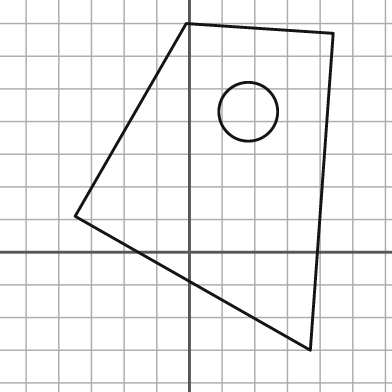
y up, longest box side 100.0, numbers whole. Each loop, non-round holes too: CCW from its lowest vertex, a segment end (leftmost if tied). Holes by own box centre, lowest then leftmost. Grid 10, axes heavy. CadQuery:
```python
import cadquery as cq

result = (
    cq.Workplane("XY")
    .moveTo(37.0, -30.0)
    .lineTo(44.0, 67.0)
    .lineTo(-1.0, 70.0)
    .lineTo(-35.0, 11.0)
    .close()
    .moveTo(18.0, 43.0)
    .circle(9.0)
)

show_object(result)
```